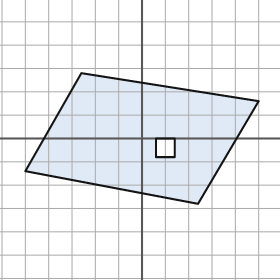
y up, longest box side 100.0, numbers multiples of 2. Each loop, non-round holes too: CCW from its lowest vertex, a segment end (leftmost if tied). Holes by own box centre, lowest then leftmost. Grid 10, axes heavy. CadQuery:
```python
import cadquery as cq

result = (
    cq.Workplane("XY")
    .moveTo(24.0, -28.0)
    .lineTo(50.0, 16.0)
    .lineTo(-26.0, 28.0)
    .lineTo(-50.0, -14.0)
    .close()
    .moveTo(6.0, -8.0)
    .lineTo(14.0, -8.0)
    .lineTo(14.0, 0.0)
    .lineTo(6.0, 0.0)
    .close()
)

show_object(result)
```